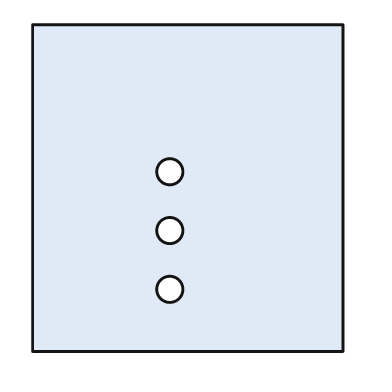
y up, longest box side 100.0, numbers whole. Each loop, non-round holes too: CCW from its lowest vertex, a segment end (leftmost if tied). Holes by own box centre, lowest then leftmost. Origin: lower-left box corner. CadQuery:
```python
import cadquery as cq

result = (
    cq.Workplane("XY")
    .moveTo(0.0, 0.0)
    .lineTo(95.0, 0.0)
    .lineTo(95.0, 100.0)
    .lineTo(0.0, 100.0)
    .close()
    .moveTo(42.0, 19.0)
    .circle(4.0)
    .moveTo(42.0, 37.0)
    .circle(4.0)
    .moveTo(42.0, 55.0)
    .circle(4.0)
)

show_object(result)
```